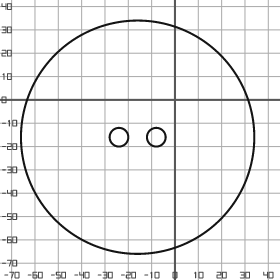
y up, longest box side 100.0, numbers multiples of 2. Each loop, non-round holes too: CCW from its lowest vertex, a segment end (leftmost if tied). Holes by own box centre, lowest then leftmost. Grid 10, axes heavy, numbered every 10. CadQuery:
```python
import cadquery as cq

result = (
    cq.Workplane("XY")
    .moveTo(-16.0, -16.0)
    .circle(50.0)
    .moveTo(-24.0, -16.0)
    .circle(4.0)
    .moveTo(-8.0, -16.0)
    .circle(4.0)
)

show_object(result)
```